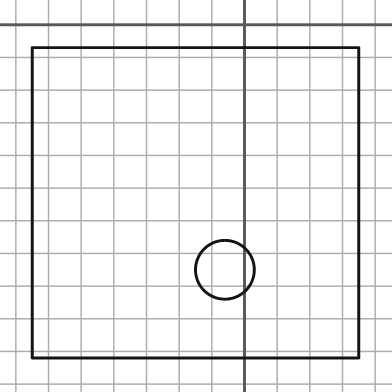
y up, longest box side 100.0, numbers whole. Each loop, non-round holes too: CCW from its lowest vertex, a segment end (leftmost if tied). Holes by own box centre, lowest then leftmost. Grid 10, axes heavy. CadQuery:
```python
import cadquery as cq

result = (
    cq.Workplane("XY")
    .moveTo(-65.0, -102.0)
    .lineTo(35.0, -102.0)
    .lineTo(35.0, -7.0)
    .lineTo(-65.0, -7.0)
    .close()
    .moveTo(-6.0, -75.0)
    .circle(9.0)
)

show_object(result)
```